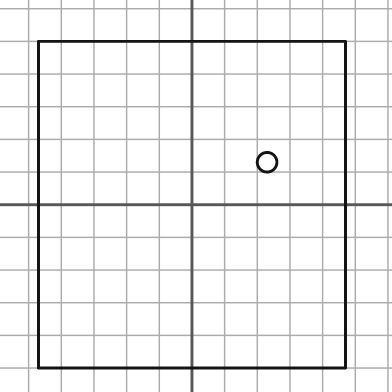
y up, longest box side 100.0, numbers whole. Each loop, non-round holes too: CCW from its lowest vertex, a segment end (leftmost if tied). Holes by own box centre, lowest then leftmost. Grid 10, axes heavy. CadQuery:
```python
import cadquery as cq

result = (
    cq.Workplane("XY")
    .moveTo(-47.0, -50.0)
    .lineTo(47.0, -50.0)
    .lineTo(47.0, 50.0)
    .lineTo(-47.0, 50.0)
    .close()
    .moveTo(23.0, 13.0)
    .circle(3.0)
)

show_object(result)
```